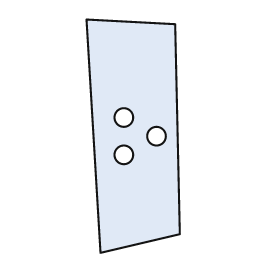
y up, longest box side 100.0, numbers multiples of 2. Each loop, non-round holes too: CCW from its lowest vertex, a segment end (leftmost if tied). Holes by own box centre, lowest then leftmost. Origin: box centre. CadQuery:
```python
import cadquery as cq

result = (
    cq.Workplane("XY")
    .moveTo(-14.0, -50.0)
    .lineTo(20.0, -42.0)
    .lineTo(18.0, 48.0)
    .lineTo(-20.0, 50.0)
    .close()
    .moveTo(-4.0, -8.0)
    .circle(4.0)
    .moveTo(10.0, 0.0)
    .circle(4.0)
    .moveTo(-4.0, 8.0)
    .circle(4.0)
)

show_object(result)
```